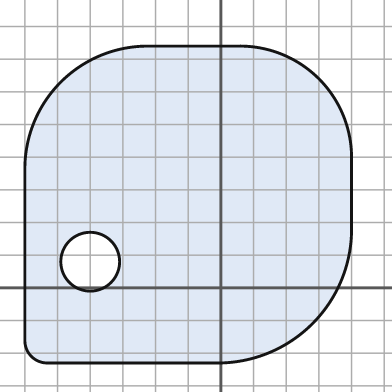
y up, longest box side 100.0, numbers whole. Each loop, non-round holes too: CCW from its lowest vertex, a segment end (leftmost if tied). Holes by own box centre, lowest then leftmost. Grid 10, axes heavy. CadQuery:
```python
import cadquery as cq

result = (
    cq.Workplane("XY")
    .moveTo(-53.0, -23.0)
    .lineTo(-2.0, -23.0)
    .threePointArc((28.0, -11.0), (40.0, 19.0))
    .lineTo(40.0, 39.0)
    .threePointArc((30.0, 64.0), (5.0, 74.0))
    .lineTo(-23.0, 74.0)
    .threePointArc((-49.0, 63.0), (-60.0, 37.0))
    .lineTo(-60.0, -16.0)
    .threePointArc((-58.0, -21.0), (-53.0, -23.0))
    .close()
    .moveTo(-40.0, 8.0)
    .circle(9.0)
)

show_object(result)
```